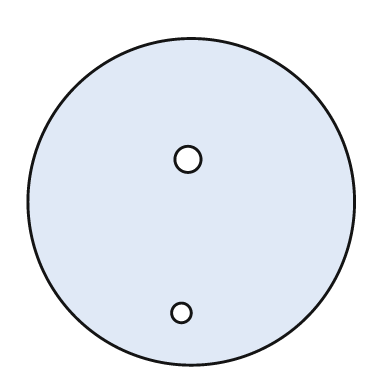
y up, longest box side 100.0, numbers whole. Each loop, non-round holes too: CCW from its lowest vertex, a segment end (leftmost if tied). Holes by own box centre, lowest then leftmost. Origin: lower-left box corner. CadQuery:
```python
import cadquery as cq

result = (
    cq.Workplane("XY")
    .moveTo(50.0, 50.0)
    .circle(50.0)
    .moveTo(47.0, 16.0)
    .circle(3.0)
    .moveTo(49.0, 63.0)
    .circle(4.0)
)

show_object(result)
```